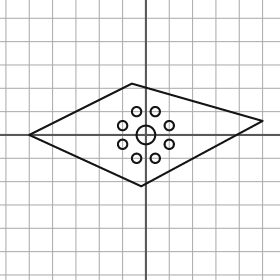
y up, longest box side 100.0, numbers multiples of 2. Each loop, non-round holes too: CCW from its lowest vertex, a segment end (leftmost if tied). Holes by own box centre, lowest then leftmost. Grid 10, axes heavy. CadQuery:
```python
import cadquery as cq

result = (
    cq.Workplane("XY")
    .moveTo(-2.0, -22.0)
    .lineTo(50.0, 6.0)
    .lineTo(-6.0, 22.0)
    .lineTo(-50.0, 0.0)
    .close()
    .moveTo(-4.0, -10.0)
    .circle(2.0)
    .moveTo(4.0, -10.0)
    .circle(2.0)
    .moveTo(-10.0, -4.0)
    .circle(2.0)
    .moveTo(10.0, -4.0)
    .circle(2.0)
    .moveTo(0.0, 0.0)
    .circle(4.0)
    .moveTo(-10.0, 4.0)
    .circle(2.0)
    .moveTo(10.0, 4.0)
    .circle(2.0)
    .moveTo(-4.0, 10.0)
    .circle(2.0)
    .moveTo(4.0, 10.0)
    .circle(2.0)
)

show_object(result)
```